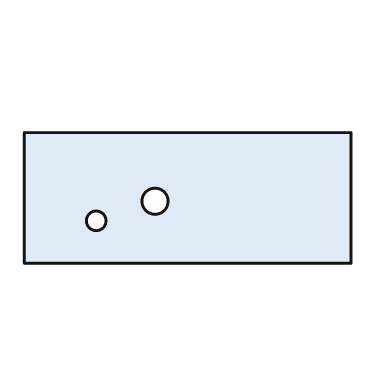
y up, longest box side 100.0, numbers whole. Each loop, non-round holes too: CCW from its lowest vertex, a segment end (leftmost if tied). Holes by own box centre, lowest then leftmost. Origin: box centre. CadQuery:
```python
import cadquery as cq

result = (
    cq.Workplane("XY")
    .moveTo(-50.0, -20.0)
    .lineTo(50.0, -20.0)
    .lineTo(50.0, 20.0)
    .lineTo(-50.0, 20.0)
    .close()
    .moveTo(-28.0, -7.0)
    .circle(3.0)
    .moveTo(-10.0, -1.0)
    .circle(4.0)
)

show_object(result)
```